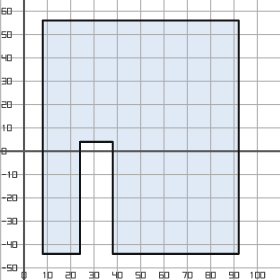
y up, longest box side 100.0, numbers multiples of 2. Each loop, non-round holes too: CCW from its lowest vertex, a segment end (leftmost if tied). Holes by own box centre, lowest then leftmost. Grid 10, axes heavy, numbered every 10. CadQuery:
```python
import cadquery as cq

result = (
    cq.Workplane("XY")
    .moveTo(8.0, -44.0)
    .lineTo(24.0, -44.0)
    .lineTo(24.0, 4.0)
    .lineTo(38.0, 4.0)
    .lineTo(38.0, -44.0)
    .lineTo(92.0, -44.0)
    .lineTo(92.0, 56.0)
    .lineTo(8.0, 56.0)
    .close()
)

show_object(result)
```